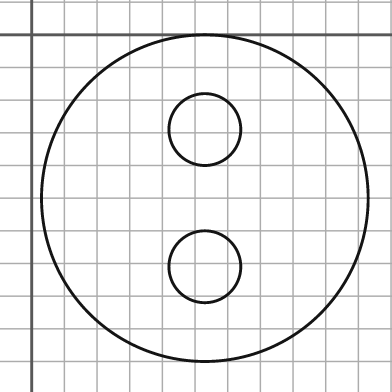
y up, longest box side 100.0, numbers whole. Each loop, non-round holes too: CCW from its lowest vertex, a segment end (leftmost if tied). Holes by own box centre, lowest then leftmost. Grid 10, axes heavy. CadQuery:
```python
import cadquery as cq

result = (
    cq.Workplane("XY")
    .moveTo(53.0, -50.0)
    .circle(50.0)
    .moveTo(53.0, -71.0)
    .circle(11.0)
    .moveTo(53.0, -29.0)
    .circle(11.0)
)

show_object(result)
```